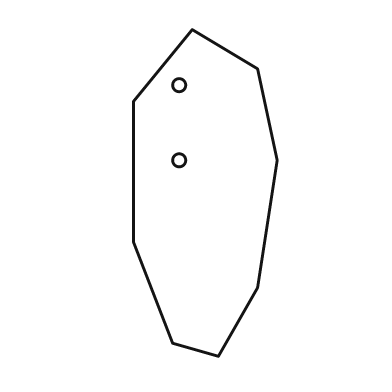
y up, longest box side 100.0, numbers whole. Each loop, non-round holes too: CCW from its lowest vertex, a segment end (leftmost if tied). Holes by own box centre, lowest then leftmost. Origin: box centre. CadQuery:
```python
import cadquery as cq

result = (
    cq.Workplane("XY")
    .moveTo(4.0, -50.0)
    .lineTo(16.0, -29.0)
    .lineTo(22.0, 10.0)
    .lineTo(16.0, 38.0)
    .lineTo(-4.0, 50.0)
    .lineTo(-22.0, 28.0)
    .lineTo(-22.0, -15.0)
    .lineTo(-10.0, -46.0)
    .close()
    .moveTo(-8.0, 10.0)
    .circle(2.0)
    .moveTo(-8.0, 33.0)
    .circle(2.0)
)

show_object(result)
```